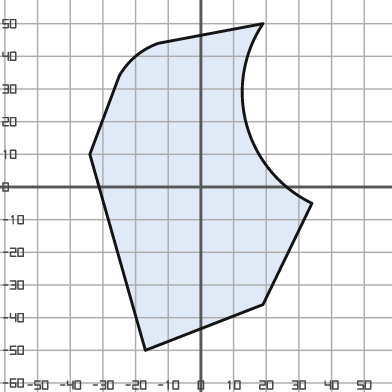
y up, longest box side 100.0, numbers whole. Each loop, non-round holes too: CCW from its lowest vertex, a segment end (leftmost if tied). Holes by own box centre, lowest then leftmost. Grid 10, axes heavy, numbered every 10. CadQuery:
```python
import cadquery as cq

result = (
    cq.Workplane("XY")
    .moveTo(-17.0, -50.0)
    .lineTo(19.0, -36.0)
    .lineTo(34.0, -5.0)
    .threePointArc((14.0, 19.0), (19.0, 50.0))
    .lineTo(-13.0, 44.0)
    .threePointArc((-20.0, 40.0), (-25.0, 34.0))
    .lineTo(-34.0, 10.0)
    .close()
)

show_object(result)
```